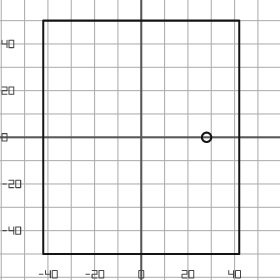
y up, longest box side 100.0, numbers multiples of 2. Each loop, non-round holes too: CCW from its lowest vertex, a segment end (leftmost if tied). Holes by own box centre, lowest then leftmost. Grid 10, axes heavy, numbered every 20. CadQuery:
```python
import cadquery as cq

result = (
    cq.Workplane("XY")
    .moveTo(-42.0, -50.0)
    .lineTo(42.0, -50.0)
    .lineTo(42.0, 50.0)
    .lineTo(-42.0, 50.0)
    .close()
    .moveTo(28.0, 0.0)
    .circle(2.0)
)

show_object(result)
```